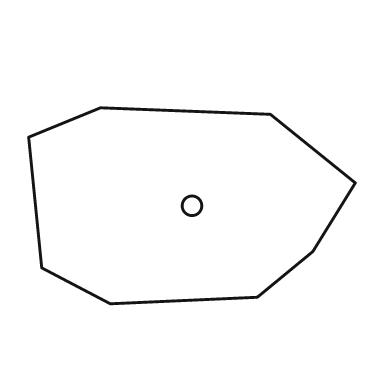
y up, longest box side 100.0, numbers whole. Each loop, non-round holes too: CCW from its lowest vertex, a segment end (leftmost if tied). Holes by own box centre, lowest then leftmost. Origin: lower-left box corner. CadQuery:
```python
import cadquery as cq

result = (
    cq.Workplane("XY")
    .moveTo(25.0, 0.0)
    .lineTo(70.0, 2.0)
    .lineTo(87.0, 16.0)
    .lineTo(100.0, 37.0)
    .lineTo(74.0, 58.0)
    .lineTo(22.0, 60.0)
    .lineTo(0.0, 51.0)
    .lineTo(4.0, 11.0)
    .close()
    .moveTo(50.0, 30.0)
    .circle(3.0)
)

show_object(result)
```